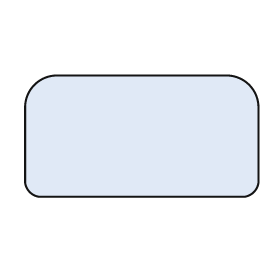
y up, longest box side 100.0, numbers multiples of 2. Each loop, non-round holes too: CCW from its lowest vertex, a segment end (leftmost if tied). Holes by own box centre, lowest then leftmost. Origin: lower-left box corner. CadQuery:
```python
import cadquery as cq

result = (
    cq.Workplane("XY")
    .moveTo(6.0, 0.0)
    .lineTo(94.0, 0.0)
    .threePointArc((98.0, 2.0), (100.0, 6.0))
    .lineTo(100.0, 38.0)
    .threePointArc((96.0, 48.0), (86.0, 52.0))
    .lineTo(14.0, 52.0)
    .threePointArc((4.0, 48.0), (0.0, 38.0))
    .lineTo(0.0, 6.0)
    .threePointArc((2.0, 2.0), (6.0, 0.0))
    .close()
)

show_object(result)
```